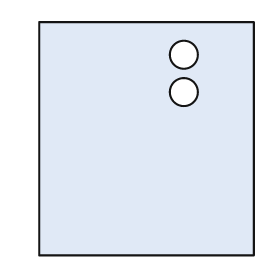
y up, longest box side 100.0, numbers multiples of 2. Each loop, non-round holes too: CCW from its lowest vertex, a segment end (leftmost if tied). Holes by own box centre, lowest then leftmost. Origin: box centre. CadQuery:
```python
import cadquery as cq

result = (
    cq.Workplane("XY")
    .moveTo(-46.0, -50.0)
    .lineTo(46.0, -50.0)
    .lineTo(46.0, 50.0)
    .lineTo(-46.0, 50.0)
    .close()
    .moveTo(16.0, 20.0)
    .circle(6.0)
    .moveTo(16.0, 36.0)
    .circle(6.0)
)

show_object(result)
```